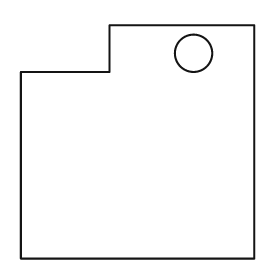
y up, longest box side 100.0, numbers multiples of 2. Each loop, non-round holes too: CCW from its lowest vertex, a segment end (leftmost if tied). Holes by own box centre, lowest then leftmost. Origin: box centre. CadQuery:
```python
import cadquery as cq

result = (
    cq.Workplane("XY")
    .moveTo(-50.0, -50.0)
    .lineTo(50.0, -50.0)
    .lineTo(50.0, 50.0)
    .lineTo(-12.0, 50.0)
    .lineTo(-12.0, 30.0)
    .lineTo(-50.0, 30.0)
    .close()
    .moveTo(24.0, 38.0)
    .circle(8.0)
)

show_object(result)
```